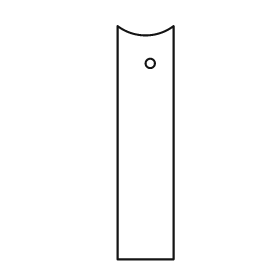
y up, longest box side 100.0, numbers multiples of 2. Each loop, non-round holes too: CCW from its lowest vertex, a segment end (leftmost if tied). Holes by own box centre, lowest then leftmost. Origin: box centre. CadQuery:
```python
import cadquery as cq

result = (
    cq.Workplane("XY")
    .moveTo(-12.0, -50.0)
    .lineTo(12.0, -50.0)
    .lineTo(12.0, 50.0)
    .threePointArc((0.0, 46.0), (-12.0, 50.0))
    .close()
    .moveTo(2.0, 34.0)
    .circle(2.0)
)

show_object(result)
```